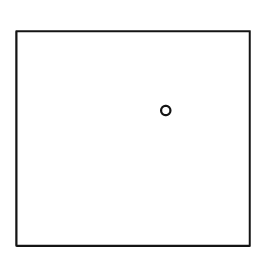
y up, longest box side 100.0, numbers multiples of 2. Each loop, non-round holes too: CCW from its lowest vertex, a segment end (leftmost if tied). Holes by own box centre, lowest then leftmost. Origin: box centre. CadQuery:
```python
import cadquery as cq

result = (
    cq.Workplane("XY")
    .moveTo(-50.0, -46.0)
    .lineTo(50.0, -46.0)
    .lineTo(50.0, 46.0)
    .lineTo(-50.0, 46.0)
    .close()
    .moveTo(14.0, 12.0)
    .circle(2.0)
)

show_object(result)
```